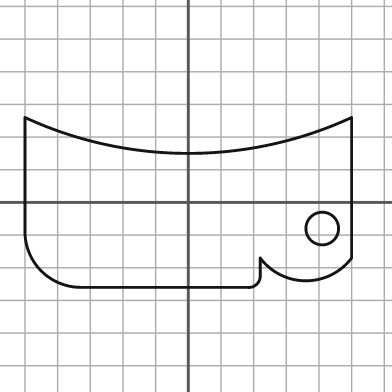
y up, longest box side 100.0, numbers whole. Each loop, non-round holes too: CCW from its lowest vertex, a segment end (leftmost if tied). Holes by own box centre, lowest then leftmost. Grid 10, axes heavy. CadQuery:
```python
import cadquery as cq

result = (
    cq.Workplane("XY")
    .moveTo(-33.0, -26.0)
    .lineTo(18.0, -26.0)
    .threePointArc((21.0, -25.0), (22.0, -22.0))
    .lineTo(22.0, -17.0)
    .threePointArc((36.0, -24.0), (50.0, -17.0))
    .lineTo(50.0, 26.0)
    .threePointArc((0.0, 15.0), (-50.0, 26.0))
    .lineTo(-50.0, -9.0)
    .threePointArc((-45.0, -21.0), (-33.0, -26.0))
    .close()
    .moveTo(41.0, -8.0)
    .circle(5.0)
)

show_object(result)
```